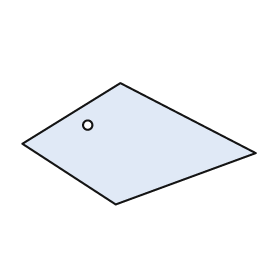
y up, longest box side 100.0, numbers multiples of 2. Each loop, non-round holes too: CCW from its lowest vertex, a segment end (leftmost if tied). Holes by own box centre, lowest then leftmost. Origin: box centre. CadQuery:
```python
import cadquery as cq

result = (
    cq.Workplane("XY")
    .moveTo(-10.0, -26.0)
    .lineTo(50.0, -4.0)
    .lineTo(-8.0, 26.0)
    .lineTo(-50.0, 0.0)
    .close()
    .moveTo(-22.0, 8.0)
    .circle(2.0)
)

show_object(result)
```